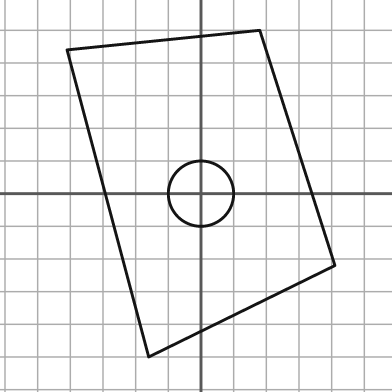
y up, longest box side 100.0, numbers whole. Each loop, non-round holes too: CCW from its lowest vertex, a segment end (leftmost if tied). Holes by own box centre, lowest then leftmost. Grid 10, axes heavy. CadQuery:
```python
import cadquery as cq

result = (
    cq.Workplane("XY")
    .moveTo(-16.0, -50.0)
    .lineTo(41.0, -22.0)
    .lineTo(18.0, 50.0)
    .lineTo(-41.0, 44.0)
    .close()
    .moveTo(0.0, 0.0)
    .circle(10.0)
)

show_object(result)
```